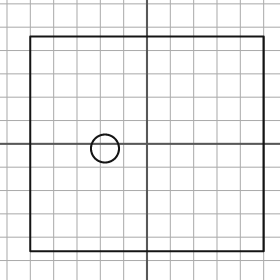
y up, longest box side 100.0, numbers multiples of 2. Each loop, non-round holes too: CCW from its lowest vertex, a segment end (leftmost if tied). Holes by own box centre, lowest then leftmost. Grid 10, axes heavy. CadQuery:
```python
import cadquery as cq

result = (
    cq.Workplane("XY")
    .moveTo(-50.0, -46.0)
    .lineTo(50.0, -46.0)
    .lineTo(50.0, 46.0)
    .lineTo(-50.0, 46.0)
    .close()
    .moveTo(-18.0, -2.0)
    .circle(6.0)
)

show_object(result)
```